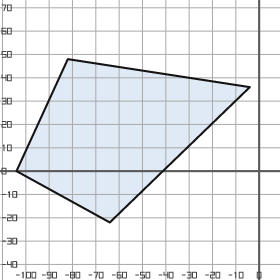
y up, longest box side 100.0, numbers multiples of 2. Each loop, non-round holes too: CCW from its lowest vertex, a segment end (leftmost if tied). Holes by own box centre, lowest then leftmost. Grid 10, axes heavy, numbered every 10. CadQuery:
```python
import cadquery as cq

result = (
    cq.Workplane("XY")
    .moveTo(-64.0, -22.0)
    .lineTo(-4.0, 36.0)
    .lineTo(-82.0, 48.0)
    .lineTo(-104.0, 0.0)
    .close()
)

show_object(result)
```